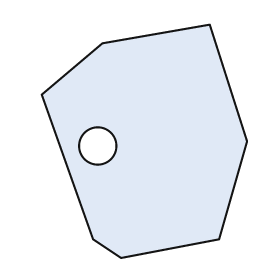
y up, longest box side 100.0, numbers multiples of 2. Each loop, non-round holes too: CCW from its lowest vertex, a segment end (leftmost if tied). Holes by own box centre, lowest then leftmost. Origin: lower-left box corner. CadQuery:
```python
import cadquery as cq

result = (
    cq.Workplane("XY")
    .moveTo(34.0, 0.0)
    .lineTo(76.0, 8.0)
    .lineTo(88.0, 50.0)
    .lineTo(72.0, 100.0)
    .lineTo(26.0, 92.0)
    .lineTo(0.0, 70.0)
    .lineTo(22.0, 8.0)
    .close()
    .moveTo(24.0, 48.0)
    .circle(8.0)
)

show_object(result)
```